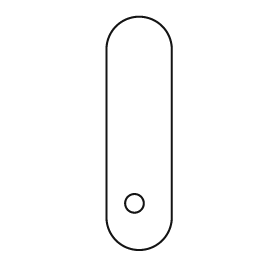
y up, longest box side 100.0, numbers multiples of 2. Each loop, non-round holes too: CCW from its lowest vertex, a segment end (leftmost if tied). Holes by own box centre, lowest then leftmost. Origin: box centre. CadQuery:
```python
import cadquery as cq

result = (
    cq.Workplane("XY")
    .moveTo(-14.0, -36.0)
    .threePointArc((0.0, -50.0), (14.0, -36.0))
    .lineTo(14.0, 36.0)
    .threePointArc((0.0, 50.0), (-14.0, 36.0))
    .close()
    .moveTo(-2.0, -30.0)
    .circle(4.0)
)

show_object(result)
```